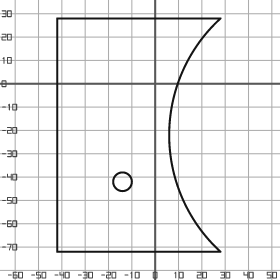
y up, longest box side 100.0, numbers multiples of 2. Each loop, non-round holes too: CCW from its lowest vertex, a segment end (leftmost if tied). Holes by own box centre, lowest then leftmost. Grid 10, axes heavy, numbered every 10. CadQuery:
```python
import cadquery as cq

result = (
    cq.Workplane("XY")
    .moveTo(-42.0, -72.0)
    .lineTo(28.0, -72.0)
    .threePointArc((6.0, -22.0), (28.0, 28.0))
    .lineTo(-42.0, 28.0)
    .close()
    .moveTo(-14.0, -42.0)
    .circle(4.0)
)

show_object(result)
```